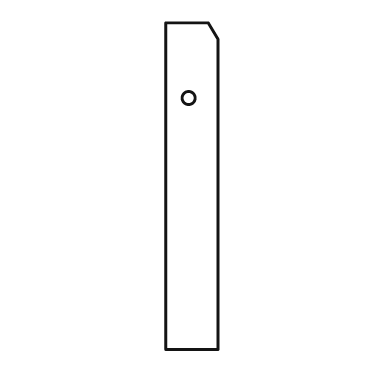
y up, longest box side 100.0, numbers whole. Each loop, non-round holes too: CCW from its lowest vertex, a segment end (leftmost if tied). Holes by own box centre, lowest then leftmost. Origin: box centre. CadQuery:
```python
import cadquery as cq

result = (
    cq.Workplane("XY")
    .moveTo(-8.0, -50.0)
    .lineTo(8.0, -50.0)
    .lineTo(8.0, 45.0)
    .lineTo(5.0, 50.0)
    .lineTo(-8.0, 50.0)
    .close()
    .moveTo(-1.0, 27.0)
    .circle(2.0)
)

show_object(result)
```